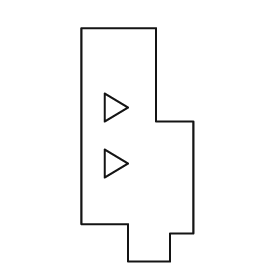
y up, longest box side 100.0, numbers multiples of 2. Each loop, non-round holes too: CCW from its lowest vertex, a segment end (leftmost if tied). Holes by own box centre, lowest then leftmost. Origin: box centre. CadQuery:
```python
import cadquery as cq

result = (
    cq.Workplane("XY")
    .moveTo(-4.0, -50.0)
    .lineTo(14.0, -50.0)
    .lineTo(14.0, -38.0)
    .lineTo(24.0, -38.0)
    .lineTo(24.0, 10.0)
    .lineTo(8.0, 10.0)
    .lineTo(8.0, 50.0)
    .lineTo(-24.0, 50.0)
    .lineTo(-24.0, -34.0)
    .lineTo(-4.0, -34.0)
    .close()
    .moveTo(-14.0, -14.0)
    .lineTo(-4.0, -8.0)
    .lineTo(-14.0, -2.0)
    .close()
    .moveTo(-14.0, 10.0)
    .lineTo(-4.0, 16.0)
    .lineTo(-14.0, 22.0)
    .close()
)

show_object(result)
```